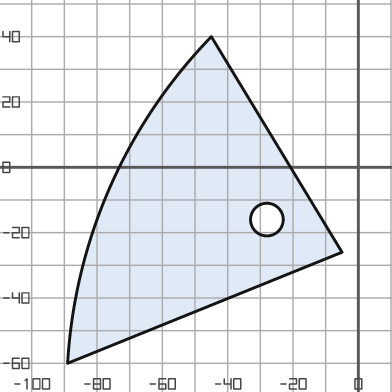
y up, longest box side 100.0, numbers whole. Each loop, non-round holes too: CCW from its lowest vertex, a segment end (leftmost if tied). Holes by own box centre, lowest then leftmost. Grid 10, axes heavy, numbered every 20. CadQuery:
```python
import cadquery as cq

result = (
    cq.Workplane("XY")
    .moveTo(-89.0, -60.0)
    .lineTo(-5.0, -26.0)
    .lineTo(-45.0, 40.0)
    .threePointArc((-76.0, -6.0), (-89.0, -60.0))
    .close()
    .moveTo(-28.0, -16.0)
    .circle(5.0)
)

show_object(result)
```